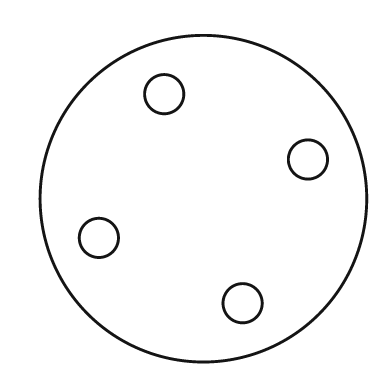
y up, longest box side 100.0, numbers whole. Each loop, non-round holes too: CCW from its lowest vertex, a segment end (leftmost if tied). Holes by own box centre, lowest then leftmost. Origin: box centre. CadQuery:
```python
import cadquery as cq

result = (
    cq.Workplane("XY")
    .moveTo(0.0, 0.0)
    .circle(50.0)
    .moveTo(12.0, -32.0)
    .circle(6.0)
    .moveTo(-32.0, -12.0)
    .circle(6.0)
    .moveTo(32.0, 12.0)
    .circle(6.0)
    .moveTo(-12.0, 32.0)
    .circle(6.0)
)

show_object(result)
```